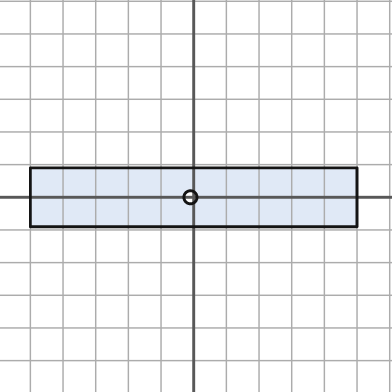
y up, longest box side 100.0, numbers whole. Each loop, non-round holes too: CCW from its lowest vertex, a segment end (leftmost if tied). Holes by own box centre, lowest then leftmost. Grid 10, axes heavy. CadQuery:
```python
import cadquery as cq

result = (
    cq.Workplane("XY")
    .moveTo(-50.0, -9.0)
    .lineTo(50.0, -9.0)
    .lineTo(50.0, 9.0)
    .lineTo(-50.0, 9.0)
    .close()
    .moveTo(-1.0, 0.0)
    .circle(2.0)
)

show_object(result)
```